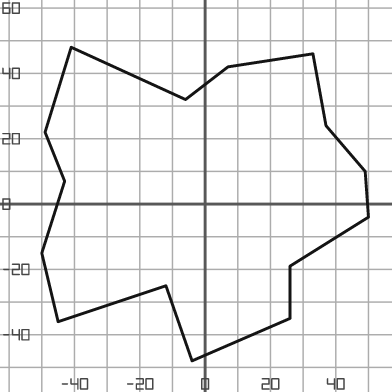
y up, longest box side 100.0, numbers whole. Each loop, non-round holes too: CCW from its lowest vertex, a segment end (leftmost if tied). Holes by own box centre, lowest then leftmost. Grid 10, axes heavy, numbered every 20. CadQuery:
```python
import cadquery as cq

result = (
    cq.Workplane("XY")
    .moveTo(-4.0, -48.0)
    .lineTo(26.0, -35.0)
    .lineTo(26.0, -19.0)
    .lineTo(50.0, -4.0)
    .lineTo(49.0, 10.0)
    .lineTo(37.0, 24.0)
    .lineTo(33.0, 46.0)
    .lineTo(7.0, 42.0)
    .lineTo(-6.0, 32.0)
    .lineTo(-41.0, 48.0)
    .lineTo(-49.0, 22.0)
    .lineTo(-43.0, 7.0)
    .lineTo(-50.0, -15.0)
    .lineTo(-45.0, -36.0)
    .lineTo(-12.0, -25.0)
    .close()
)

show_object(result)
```